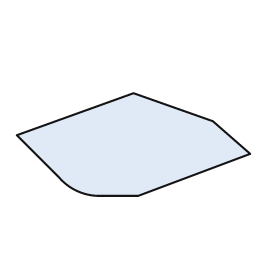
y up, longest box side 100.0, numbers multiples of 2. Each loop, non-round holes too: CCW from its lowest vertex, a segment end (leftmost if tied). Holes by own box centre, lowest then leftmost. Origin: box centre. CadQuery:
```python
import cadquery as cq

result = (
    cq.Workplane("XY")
    .moveTo(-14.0, -22.0)
    .lineTo(2.0, -22.0)
    .lineTo(50.0, -4.0)
    .lineTo(34.0, 10.0)
    .lineTo(0.0, 22.0)
    .lineTo(-50.0, 4.0)
    .lineTo(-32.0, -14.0)
    .threePointArc((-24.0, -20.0), (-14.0, -22.0))
    .close()
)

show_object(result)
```